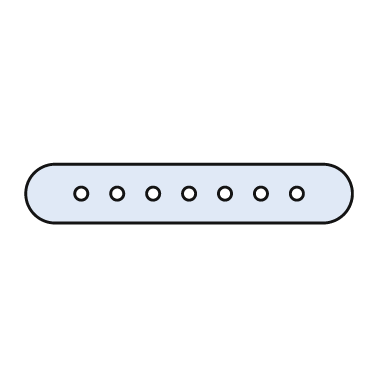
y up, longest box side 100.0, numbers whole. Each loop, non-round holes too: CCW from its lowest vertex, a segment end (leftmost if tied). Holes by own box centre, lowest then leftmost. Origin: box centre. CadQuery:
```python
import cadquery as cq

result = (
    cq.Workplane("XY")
    .moveTo(-41.0, -9.0)
    .lineTo(41.0, -9.0)
    .threePointArc((50.0, 0.0), (41.0, 9.0))
    .lineTo(-41.0, 9.0)
    .threePointArc((-50.0, 0.0), (-41.0, -9.0))
    .close()
    .moveTo(-33.0, 0.0)
    .circle(2.0)
    .moveTo(-22.0, 0.0)
    .circle(2.0)
    .moveTo(-11.0, 0.0)
    .circle(2.0)
    .moveTo(0.0, 0.0)
    .circle(2.0)
    .moveTo(11.0, 0.0)
    .circle(2.0)
    .moveTo(22.0, 0.0)
    .circle(2.0)
    .moveTo(33.0, 0.0)
    .circle(2.0)
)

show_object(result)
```